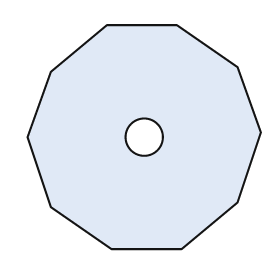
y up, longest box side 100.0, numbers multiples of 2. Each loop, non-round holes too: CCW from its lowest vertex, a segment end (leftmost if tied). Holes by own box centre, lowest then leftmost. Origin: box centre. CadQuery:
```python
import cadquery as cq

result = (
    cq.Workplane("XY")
    .moveTo(-14.0, -48.0)
    .lineTo(16.0, -48.0)
    .lineTo(40.0, -28.0)
    .lineTo(50.0, 2.0)
    .lineTo(40.0, 30.0)
    .lineTo(14.0, 48.0)
    .lineTo(-16.0, 48.0)
    .lineTo(-40.0, 28.0)
    .lineTo(-50.0, 0.0)
    .lineTo(-40.0, -30.0)
    .close()
    .moveTo(0.0, 0.0)
    .circle(8.0)
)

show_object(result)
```